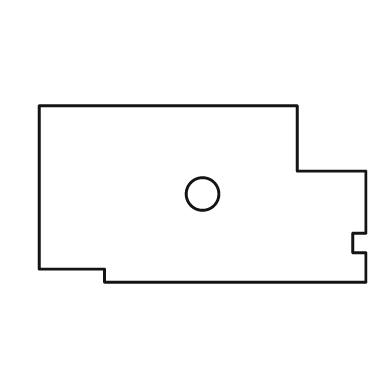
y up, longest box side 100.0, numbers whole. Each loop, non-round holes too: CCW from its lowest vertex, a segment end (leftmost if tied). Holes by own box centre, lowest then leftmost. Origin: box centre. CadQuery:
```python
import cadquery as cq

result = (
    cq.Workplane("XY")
    .moveTo(-30.0, -27.0)
    .lineTo(50.0, -27.0)
    .lineTo(50.0, -18.0)
    .lineTo(46.0, -18.0)
    .lineTo(46.0, -12.0)
    .lineTo(50.0, -12.0)
    .lineTo(50.0, 7.0)
    .lineTo(29.0, 7.0)
    .lineTo(29.0, 27.0)
    .lineTo(-50.0, 27.0)
    .lineTo(-50.0, -23.0)
    .lineTo(-30.0, -23.0)
    .close()
    .moveTo(0.0, 0.0)
    .circle(5.0)
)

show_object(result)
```